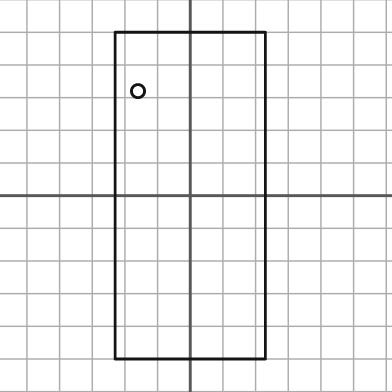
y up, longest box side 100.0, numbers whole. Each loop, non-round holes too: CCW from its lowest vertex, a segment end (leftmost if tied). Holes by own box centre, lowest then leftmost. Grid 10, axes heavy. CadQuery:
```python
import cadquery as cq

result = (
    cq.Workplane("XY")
    .moveTo(-23.0, -50.0)
    .lineTo(23.0, -50.0)
    .lineTo(23.0, 50.0)
    .lineTo(-23.0, 50.0)
    .close()
    .moveTo(-16.0, 32.0)
    .circle(2.0)
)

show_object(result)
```